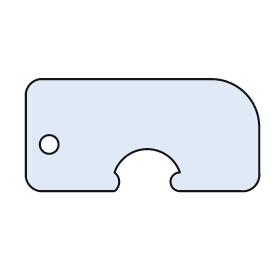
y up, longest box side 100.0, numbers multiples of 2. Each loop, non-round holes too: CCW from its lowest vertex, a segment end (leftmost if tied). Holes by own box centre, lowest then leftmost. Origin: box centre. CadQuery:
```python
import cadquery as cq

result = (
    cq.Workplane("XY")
    .moveTo(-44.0, -24.0)
    .lineTo(-12.0, -24.0)
    .threePointArc((-10.0, -20.0), (-12.0, -16.0))
    .threePointArc((2.0, -6.0), (16.0, -16.0))
    .threePointArc((12.0, -20.0), (16.0, -24.0))
    .lineTo(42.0, -24.0)
    .threePointArc((48.0, -22.0), (50.0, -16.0))
    .lineTo(50.0, 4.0)
    .threePointArc((44.0, 18.0), (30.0, 24.0))
    .lineTo(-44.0, 24.0)
    .threePointArc((-48.0, 22.0), (-50.0, 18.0))
    .lineTo(-50.0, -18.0)
    .threePointArc((-48.0, -22.0), (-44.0, -24.0))
    .close()
    .moveTo(-40.0, -4.0)
    .circle(4.0)
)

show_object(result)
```